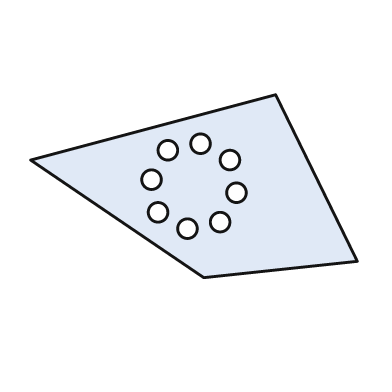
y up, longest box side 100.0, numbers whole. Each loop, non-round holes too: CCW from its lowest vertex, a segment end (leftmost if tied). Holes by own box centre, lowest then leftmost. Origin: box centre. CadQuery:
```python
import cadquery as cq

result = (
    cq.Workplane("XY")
    .moveTo(3.0, -28.0)
    .lineTo(50.0, -23.0)
    .lineTo(25.0, 28.0)
    .lineTo(-50.0, 8.0)
    .close()
    .moveTo(-2.0, -13.0)
    .circle(3.0)
    .moveTo(8.0, -11.0)
    .circle(3.0)
    .moveTo(-11.0, -8.0)
    .circle(3.0)
    .moveTo(13.0, -2.0)
    .circle(3.0)
    .moveTo(-13.0, 2.0)
    .circle(3.0)
    .moveTo(11.0, 8.0)
    .circle(3.0)
    .moveTo(-8.0, 11.0)
    .circle(3.0)
    .moveTo(2.0, 13.0)
    .circle(3.0)
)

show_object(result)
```